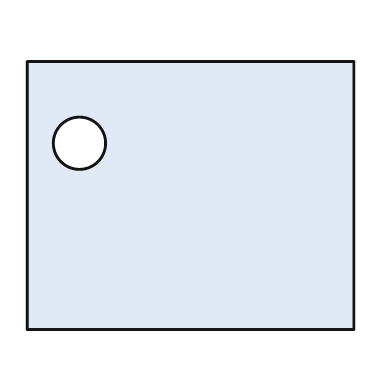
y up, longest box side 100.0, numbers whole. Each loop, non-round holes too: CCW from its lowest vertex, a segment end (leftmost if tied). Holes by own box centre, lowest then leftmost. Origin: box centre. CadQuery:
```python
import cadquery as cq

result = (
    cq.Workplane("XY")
    .moveTo(-50.0, -41.0)
    .lineTo(50.0, -41.0)
    .lineTo(50.0, 41.0)
    .lineTo(-50.0, 41.0)
    .close()
    .moveTo(-34.0, 16.0)
    .circle(8.0)
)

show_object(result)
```